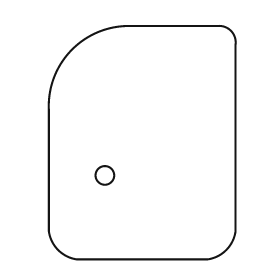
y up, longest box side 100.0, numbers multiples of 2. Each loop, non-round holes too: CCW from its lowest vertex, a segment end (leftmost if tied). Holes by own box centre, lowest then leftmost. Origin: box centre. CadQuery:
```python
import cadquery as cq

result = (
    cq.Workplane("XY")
    .moveTo(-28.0, -50.0)
    .lineTo(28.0, -50.0)
    .threePointArc((36.0, -46.0), (40.0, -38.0))
    .lineTo(40.0, 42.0)
    .threePointArc((38.0, 48.0), (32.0, 50.0))
    .lineTo(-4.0, 50.0)
    .threePointArc((-30.0, 40.0), (-40.0, 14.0))
    .lineTo(-40.0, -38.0)
    .threePointArc((-36.0, -46.0), (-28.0, -50.0))
    .close()
    .moveTo(-16.0, -14.0)
    .circle(4.0)
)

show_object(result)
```